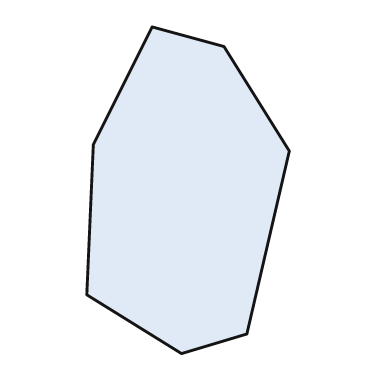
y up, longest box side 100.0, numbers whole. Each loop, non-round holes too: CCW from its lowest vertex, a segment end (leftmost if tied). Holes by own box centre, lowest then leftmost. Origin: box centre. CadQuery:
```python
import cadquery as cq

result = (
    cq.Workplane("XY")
    .moveTo(-2.0, -50.0)
    .lineTo(18.0, -44.0)
    .lineTo(31.0, 12.0)
    .lineTo(11.0, 44.0)
    .lineTo(-11.0, 50.0)
    .lineTo(-29.0, 14.0)
    .lineTo(-31.0, -32.0)
    .close()
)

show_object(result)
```